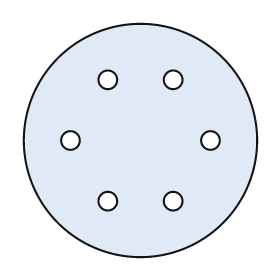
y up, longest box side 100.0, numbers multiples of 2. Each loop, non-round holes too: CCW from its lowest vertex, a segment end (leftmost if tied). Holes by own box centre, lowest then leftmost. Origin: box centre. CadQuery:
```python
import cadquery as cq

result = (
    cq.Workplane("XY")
    .moveTo(0.0, 0.0)
    .circle(50.0)
    .moveTo(-14.0, -26.0)
    .circle(4.0)
    .moveTo(14.0, -26.0)
    .circle(4.0)
    .moveTo(-30.0, 0.0)
    .circle(4.0)
    .moveTo(30.0, 0.0)
    .circle(4.0)
    .moveTo(-14.0, 26.0)
    .circle(4.0)
    .moveTo(14.0, 26.0)
    .circle(4.0)
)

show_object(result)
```